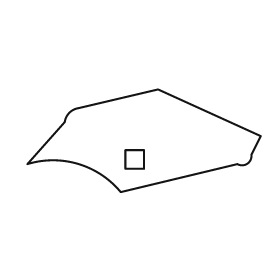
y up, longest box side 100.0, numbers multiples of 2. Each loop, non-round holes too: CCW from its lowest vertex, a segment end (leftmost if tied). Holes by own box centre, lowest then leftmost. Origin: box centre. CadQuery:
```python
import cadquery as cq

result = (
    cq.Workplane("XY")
    .moveTo(-10.0, -22.0)
    .lineTo(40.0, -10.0)
    .threePointArc((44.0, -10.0), (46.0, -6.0))
    .lineTo(50.0, 2.0)
    .lineTo(6.0, 22.0)
    .lineTo(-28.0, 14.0)
    .threePointArc((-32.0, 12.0), (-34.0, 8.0))
    .lineTo(-50.0, -10.0)
    .threePointArc((-28.0, -10.0), (-10.0, -22.0))
    .close()
    .moveTo(-8.0, -12.0)
    .lineTo(0.0, -12.0)
    .lineTo(0.0, -4.0)
    .lineTo(-8.0, -4.0)
    .close()
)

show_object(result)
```